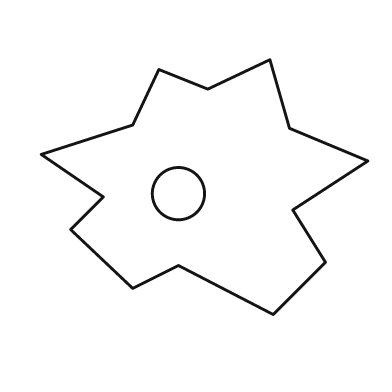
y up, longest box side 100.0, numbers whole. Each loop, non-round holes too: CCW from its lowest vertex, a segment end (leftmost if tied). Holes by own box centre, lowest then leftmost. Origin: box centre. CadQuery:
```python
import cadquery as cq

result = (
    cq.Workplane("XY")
    .moveTo(21.0, -39.0)
    .lineTo(37.0, -23.0)
    .lineTo(27.0, -7.0)
    .lineTo(50.0, 8.0)
    .lineTo(26.0, 18.0)
    .lineTo(20.0, 39.0)
    .lineTo(1.0, 30.0)
    .lineTo(-14.0, 36.0)
    .lineTo(-22.0, 19.0)
    .lineTo(-50.0, 10.0)
    .lineTo(-31.0, -3.0)
    .lineTo(-41.0, -13.0)
    .lineTo(-22.0, -31.0)
    .lineTo(-8.0, -24.0)
    .close()
    .moveTo(-8.0, -2.0)
    .circle(8.0)
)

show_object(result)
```